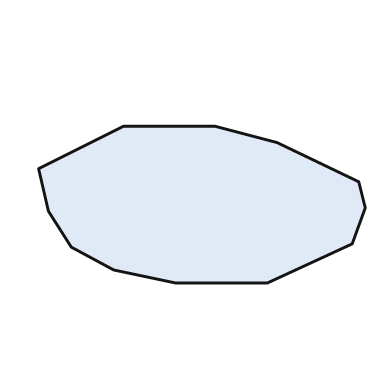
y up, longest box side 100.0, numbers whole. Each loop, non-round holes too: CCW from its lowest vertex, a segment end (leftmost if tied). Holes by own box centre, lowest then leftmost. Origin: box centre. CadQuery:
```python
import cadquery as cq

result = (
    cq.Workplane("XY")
    .moveTo(-8.0, -24.0)
    .lineTo(20.0, -24.0)
    .lineTo(46.0, -12.0)
    .lineTo(50.0, -1.0)
    .lineTo(48.0, 7.0)
    .lineTo(23.0, 19.0)
    .lineTo(4.0, 24.0)
    .lineTo(-24.0, 24.0)
    .lineTo(-50.0, 11.0)
    .lineTo(-47.0, -2.0)
    .lineTo(-40.0, -13.0)
    .lineTo(-27.0, -20.0)
    .close()
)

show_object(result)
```